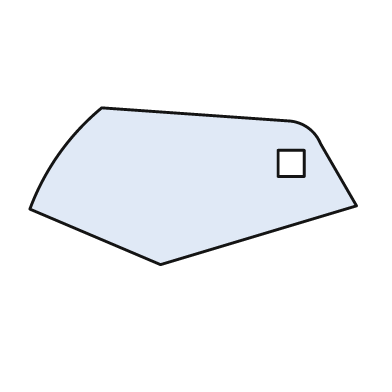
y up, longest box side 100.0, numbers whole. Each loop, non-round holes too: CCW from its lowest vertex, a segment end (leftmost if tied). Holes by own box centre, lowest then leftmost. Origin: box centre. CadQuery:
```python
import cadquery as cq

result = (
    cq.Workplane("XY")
    .moveTo(-10.0, -24.0)
    .lineTo(50.0, -6.0)
    .lineTo(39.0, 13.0)
    .threePointArc((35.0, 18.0), (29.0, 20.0))
    .lineTo(-28.0, 24.0)
    .threePointArc((-41.0, 10.0), (-50.0, -7.0))
    .close()
    .moveTo(26.0, 3.0)
    .lineTo(34.0, 3.0)
    .lineTo(34.0, 11.0)
    .lineTo(26.0, 11.0)
    .close()
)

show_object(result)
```